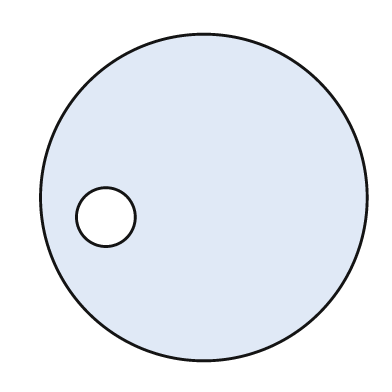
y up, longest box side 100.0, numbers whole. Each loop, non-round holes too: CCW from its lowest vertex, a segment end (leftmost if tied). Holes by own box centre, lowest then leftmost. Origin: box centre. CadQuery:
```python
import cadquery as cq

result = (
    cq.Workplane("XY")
    .moveTo(0.0, 0.0)
    .circle(50.0)
    .moveTo(-30.0, -6.0)
    .circle(9.0)
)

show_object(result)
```